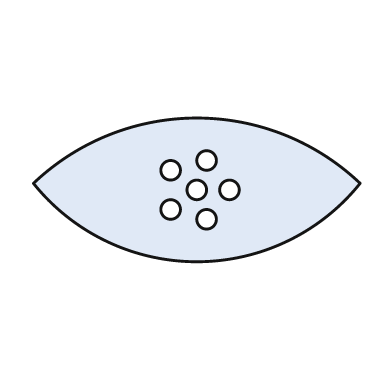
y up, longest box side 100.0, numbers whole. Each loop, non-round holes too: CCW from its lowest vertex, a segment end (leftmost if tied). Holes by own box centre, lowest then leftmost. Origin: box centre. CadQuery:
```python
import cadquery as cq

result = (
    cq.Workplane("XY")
    .moveTo(-50.0, 2.0)
    .threePointArc((0.0, -22.0), (50.0, 2.0))
    .threePointArc((0.0, 22.0), (-50.0, 2.0))
    .close()
    .moveTo(3.0, -9.0)
    .circle(3.0)
    .moveTo(-8.0, -6.0)
    .circle(3.0)
    .moveTo(0.0, 0.0)
    .circle(3.0)
    .moveTo(10.0, 0.0)
    .circle(3.0)
    .moveTo(-8.0, 6.0)
    .circle(3.0)
    .moveTo(3.0, 9.0)
    .circle(3.0)
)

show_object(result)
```